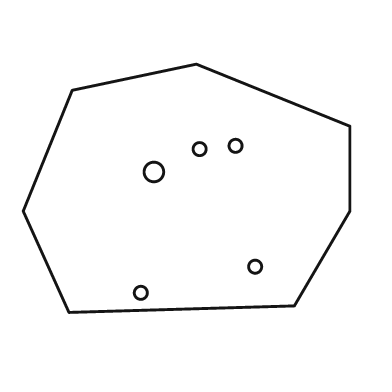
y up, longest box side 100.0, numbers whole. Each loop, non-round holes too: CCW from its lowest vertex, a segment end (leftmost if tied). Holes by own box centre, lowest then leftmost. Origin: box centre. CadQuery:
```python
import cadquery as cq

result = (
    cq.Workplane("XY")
    .moveTo(-36.0, -38.0)
    .lineTo(33.0, -36.0)
    .lineTo(50.0, -7.0)
    .lineTo(50.0, 19.0)
    .lineTo(3.0, 38.0)
    .lineTo(-35.0, 30.0)
    .lineTo(-50.0, -7.0)
    .close()
    .moveTo(-14.0, -32.0)
    .circle(2.0)
    .moveTo(21.0, -24.0)
    .circle(2.0)
    .moveTo(-10.0, 5.0)
    .circle(3.0)
    .moveTo(4.0, 12.0)
    .circle(2.0)
    .moveTo(15.0, 13.0)
    .circle(2.0)
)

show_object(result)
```